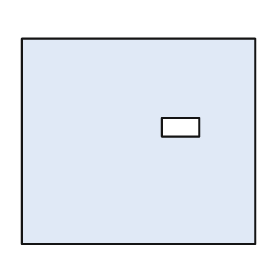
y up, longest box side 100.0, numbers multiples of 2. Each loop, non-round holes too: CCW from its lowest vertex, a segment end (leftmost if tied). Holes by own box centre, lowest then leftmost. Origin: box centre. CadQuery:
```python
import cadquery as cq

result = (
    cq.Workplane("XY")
    .moveTo(-50.0, -44.0)
    .lineTo(50.0, -44.0)
    .lineTo(50.0, 44.0)
    .lineTo(-50.0, 44.0)
    .close()
    .moveTo(10.0, 2.0)
    .lineTo(26.0, 2.0)
    .lineTo(26.0, 10.0)
    .lineTo(10.0, 10.0)
    .close()
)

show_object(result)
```